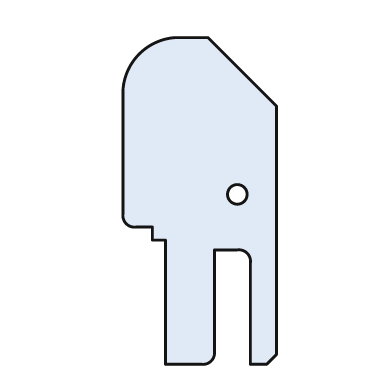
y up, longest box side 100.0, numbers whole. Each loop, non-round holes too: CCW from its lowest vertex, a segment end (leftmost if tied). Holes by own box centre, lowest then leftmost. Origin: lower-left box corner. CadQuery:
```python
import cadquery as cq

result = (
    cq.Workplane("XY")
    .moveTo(13.0, 0.0)
    .lineTo(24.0, 0.0)
    .threePointArc((27.0, 1.0), (28.0, 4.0))
    .lineTo(28.0, 35.0)
    .lineTo(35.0, 35.0)
    .threePointArc((38.0, 34.0), (39.0, 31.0))
    .lineTo(39.0, 0.0)
    .lineTo(44.0, 0.0)
    .lineTo(47.0, 3.0)
    .lineTo(47.0, 79.0)
    .lineTo(26.0, 100.0)
    .lineTo(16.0, 100.0)
    .threePointArc((5.0, 95.0), (0.0, 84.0))
    .lineTo(0.0, 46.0)
    .threePointArc((1.0, 43.0), (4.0, 42.0))
    .lineTo(9.0, 42.0)
    .lineTo(9.0, 38.0)
    .lineTo(13.0, 38.0)
    .close()
    .moveTo(35.0, 52.0)
    .circle(3.0)
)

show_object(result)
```